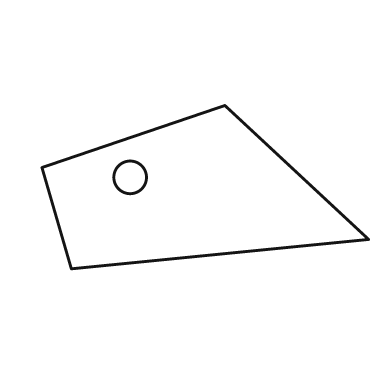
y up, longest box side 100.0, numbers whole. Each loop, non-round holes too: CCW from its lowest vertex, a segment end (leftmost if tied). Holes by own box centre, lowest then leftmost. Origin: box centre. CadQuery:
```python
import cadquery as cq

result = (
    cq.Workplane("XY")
    .moveTo(-41.0, -25.0)
    .lineTo(50.0, -16.0)
    .lineTo(6.0, 25.0)
    .lineTo(-50.0, 6.0)
    .close()
    .moveTo(-23.0, 3.0)
    .circle(5.0)
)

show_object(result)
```